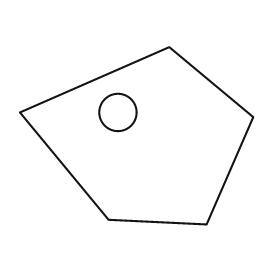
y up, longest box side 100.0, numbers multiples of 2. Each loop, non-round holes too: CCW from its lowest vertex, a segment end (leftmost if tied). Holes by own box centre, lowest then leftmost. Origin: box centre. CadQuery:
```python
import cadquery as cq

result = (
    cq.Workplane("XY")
    .moveTo(30.0, -38.0)
    .lineTo(50.0, 8.0)
    .lineTo(14.0, 38.0)
    .lineTo(-50.0, 10.0)
    .lineTo(-12.0, -36.0)
    .close()
    .moveTo(-8.0, 10.0)
    .circle(8.0)
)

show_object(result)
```